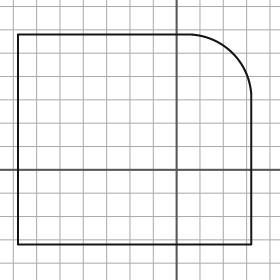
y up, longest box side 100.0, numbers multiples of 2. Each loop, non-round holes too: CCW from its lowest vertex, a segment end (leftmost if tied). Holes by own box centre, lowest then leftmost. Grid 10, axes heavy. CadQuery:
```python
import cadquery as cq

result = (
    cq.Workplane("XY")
    .moveTo(-68.0, -32.0)
    .lineTo(32.0, -32.0)
    .lineTo(32.0, 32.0)
    .threePointArc((24.0, 50.0), (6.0, 58.0))
    .lineTo(-68.0, 58.0)
    .close()
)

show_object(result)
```